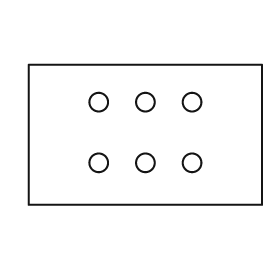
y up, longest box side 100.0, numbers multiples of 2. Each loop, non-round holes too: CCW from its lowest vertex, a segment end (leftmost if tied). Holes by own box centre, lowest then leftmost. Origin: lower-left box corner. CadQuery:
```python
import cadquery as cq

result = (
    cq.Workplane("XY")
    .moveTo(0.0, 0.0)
    .lineTo(100.0, 0.0)
    .lineTo(100.0, 60.0)
    .lineTo(0.0, 60.0)
    .close()
    .moveTo(30.0, 18.0)
    .circle(4.0)
    .moveTo(50.0, 18.0)
    .circle(4.0)
    .moveTo(70.0, 18.0)
    .circle(4.0)
    .moveTo(30.0, 44.0)
    .circle(4.0)
    .moveTo(50.0, 44.0)
    .circle(4.0)
    .moveTo(70.0, 44.0)
    .circle(4.0)
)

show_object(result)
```